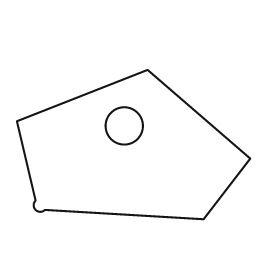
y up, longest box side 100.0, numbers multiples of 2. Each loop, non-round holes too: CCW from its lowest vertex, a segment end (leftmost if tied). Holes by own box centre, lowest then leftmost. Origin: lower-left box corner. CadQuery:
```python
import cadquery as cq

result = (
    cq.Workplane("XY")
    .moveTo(80.0, 0.0)
    .lineTo(100.0, 26.0)
    .lineTo(56.0, 64.0)
    .lineTo(0.0, 42.0)
    .lineTo(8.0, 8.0)
    .threePointArc((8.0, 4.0), (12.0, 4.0))
    .close()
    .moveTo(46.0, 40.0)
    .circle(8.0)
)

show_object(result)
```